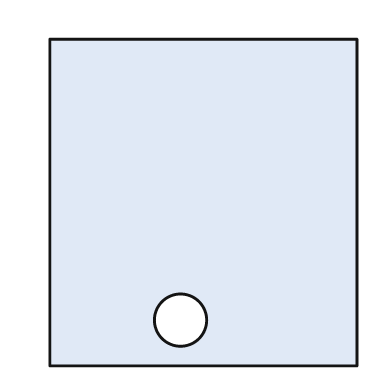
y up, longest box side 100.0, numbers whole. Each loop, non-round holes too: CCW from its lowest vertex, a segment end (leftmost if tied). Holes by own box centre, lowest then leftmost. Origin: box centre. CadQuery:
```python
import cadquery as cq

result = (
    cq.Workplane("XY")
    .moveTo(-47.0, -50.0)
    .lineTo(47.0, -50.0)
    .lineTo(47.0, 50.0)
    .lineTo(-47.0, 50.0)
    .close()
    .moveTo(-7.0, -36.0)
    .circle(8.0)
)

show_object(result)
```